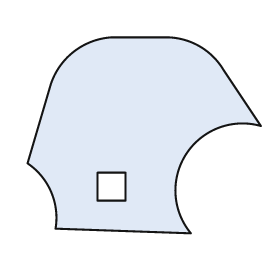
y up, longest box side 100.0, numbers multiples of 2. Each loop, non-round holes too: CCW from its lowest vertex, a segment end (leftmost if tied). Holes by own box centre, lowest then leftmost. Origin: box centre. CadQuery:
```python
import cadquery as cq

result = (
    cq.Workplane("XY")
    .moveTo(20.0, -42.0)
    .threePointArc((18.0, -8.0), (50.0, 4.0))
    .lineTo(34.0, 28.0)
    .threePointArc((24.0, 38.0), (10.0, 42.0))
    .lineTo(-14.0, 42.0)
    .threePointArc((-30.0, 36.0), (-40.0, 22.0))
    .lineTo(-50.0, -12.0)
    .threePointArc((-40.0, -24.0), (-38.0, -40.0))
    .close()
    .moveTo(-20.0, -28.0)
    .lineTo(-8.0, -28.0)
    .lineTo(-8.0, -16.0)
    .lineTo(-20.0, -16.0)
    .close()
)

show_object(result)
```